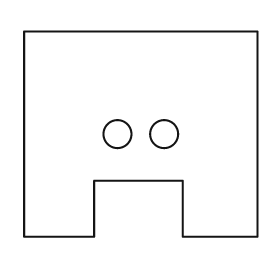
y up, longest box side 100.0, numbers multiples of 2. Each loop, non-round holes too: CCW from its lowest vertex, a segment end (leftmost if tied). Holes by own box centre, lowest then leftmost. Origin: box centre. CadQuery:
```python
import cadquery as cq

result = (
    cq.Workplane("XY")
    .moveTo(-50.0, -44.0)
    .lineTo(-20.0, -44.0)
    .lineTo(-20.0, -20.0)
    .lineTo(18.0, -20.0)
    .lineTo(18.0, -44.0)
    .lineTo(50.0, -44.0)
    .lineTo(50.0, 44.0)
    .lineTo(-50.0, 44.0)
    .close()
    .moveTo(-10.0, 0.0)
    .circle(6.0)
    .moveTo(10.0, 0.0)
    .circle(6.0)
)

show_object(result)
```